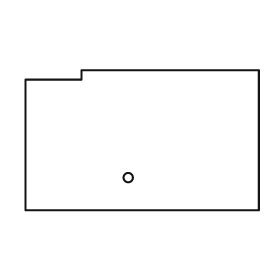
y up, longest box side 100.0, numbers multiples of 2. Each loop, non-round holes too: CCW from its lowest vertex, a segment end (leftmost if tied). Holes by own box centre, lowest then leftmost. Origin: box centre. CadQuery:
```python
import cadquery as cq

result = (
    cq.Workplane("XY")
    .moveTo(-50.0, -30.0)
    .lineTo(50.0, -30.0)
    .lineTo(50.0, 30.0)
    .lineTo(-26.0, 30.0)
    .lineTo(-26.0, 26.0)
    .lineTo(-50.0, 26.0)
    .close()
    .moveTo(-6.0, -16.0)
    .circle(2.0)
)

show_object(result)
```